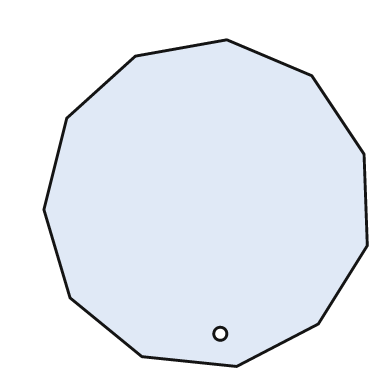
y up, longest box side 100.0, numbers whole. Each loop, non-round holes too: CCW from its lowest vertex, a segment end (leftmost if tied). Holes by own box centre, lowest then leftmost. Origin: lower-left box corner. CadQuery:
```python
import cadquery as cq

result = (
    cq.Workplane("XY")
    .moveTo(59.0, 0.0)
    .lineTo(84.0, 13.0)
    .lineTo(99.0, 37.0)
    .lineTo(98.0, 65.0)
    .lineTo(82.0, 89.0)
    .lineTo(56.0, 100.0)
    .lineTo(28.0, 95.0)
    .lineTo(7.0, 76.0)
    .lineTo(0.0, 48.0)
    .lineTo(8.0, 21.0)
    .lineTo(30.0, 3.0)
    .close()
    .moveTo(54.0, 10.0)
    .circle(2.0)
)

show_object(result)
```